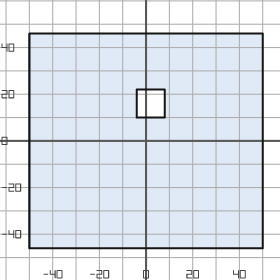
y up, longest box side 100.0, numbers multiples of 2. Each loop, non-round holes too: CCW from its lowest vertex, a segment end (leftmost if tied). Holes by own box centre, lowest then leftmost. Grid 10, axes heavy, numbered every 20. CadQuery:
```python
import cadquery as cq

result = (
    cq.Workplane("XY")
    .moveTo(-50.0, -46.0)
    .lineTo(50.0, -46.0)
    .lineTo(50.0, 46.0)
    .lineTo(-50.0, 46.0)
    .close()
    .moveTo(-4.0, 10.0)
    .lineTo(8.0, 10.0)
    .lineTo(8.0, 22.0)
    .lineTo(-4.0, 22.0)
    .close()
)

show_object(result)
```